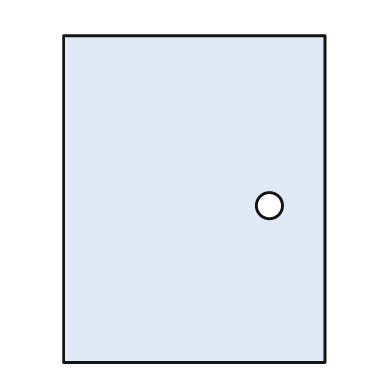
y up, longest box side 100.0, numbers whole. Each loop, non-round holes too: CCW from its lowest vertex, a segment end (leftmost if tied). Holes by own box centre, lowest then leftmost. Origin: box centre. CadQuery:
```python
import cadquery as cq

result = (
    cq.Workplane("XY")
    .moveTo(-40.0, -50.0)
    .lineTo(40.0, -50.0)
    .lineTo(40.0, 50.0)
    .lineTo(-40.0, 50.0)
    .close()
    .moveTo(23.0, -2.0)
    .circle(4.0)
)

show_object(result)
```